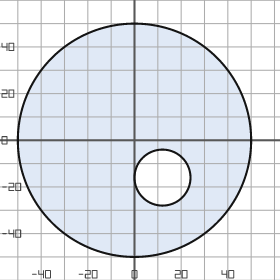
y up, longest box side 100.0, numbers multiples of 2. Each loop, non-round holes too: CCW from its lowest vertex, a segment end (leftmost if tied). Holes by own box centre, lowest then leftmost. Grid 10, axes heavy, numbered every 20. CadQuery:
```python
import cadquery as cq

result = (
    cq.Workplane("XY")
    .moveTo(0.0, 0.0)
    .circle(50.0)
    .moveTo(12.0, -16.0)
    .circle(12.0)
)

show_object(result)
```